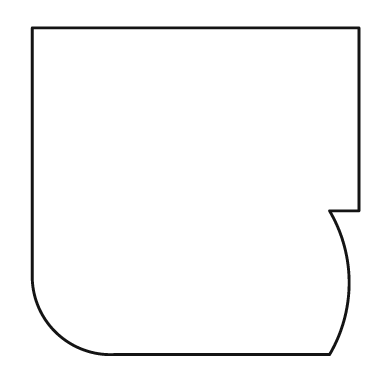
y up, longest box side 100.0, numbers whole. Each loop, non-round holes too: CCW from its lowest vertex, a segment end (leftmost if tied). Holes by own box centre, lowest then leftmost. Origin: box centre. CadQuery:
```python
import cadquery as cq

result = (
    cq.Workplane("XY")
    .moveTo(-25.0, -50.0)
    .lineTo(41.0, -50.0)
    .threePointArc((47.0, -28.0), (41.0, -6.0))
    .lineTo(50.0, -6.0)
    .lineTo(50.0, 50.0)
    .lineTo(-50.0, 50.0)
    .lineTo(-50.0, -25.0)
    .threePointArc((-43.0, -43.0), (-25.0, -50.0))
    .close()
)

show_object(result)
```